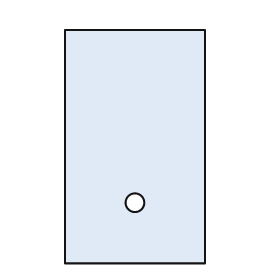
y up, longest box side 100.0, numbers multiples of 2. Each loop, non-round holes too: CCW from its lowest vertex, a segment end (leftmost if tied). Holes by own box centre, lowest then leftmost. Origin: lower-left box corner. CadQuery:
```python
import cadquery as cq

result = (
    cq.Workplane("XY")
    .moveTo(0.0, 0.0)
    .lineTo(60.0, 0.0)
    .lineTo(60.0, 100.0)
    .lineTo(0.0, 100.0)
    .close()
    .moveTo(30.0, 26.0)
    .circle(4.0)
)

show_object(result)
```